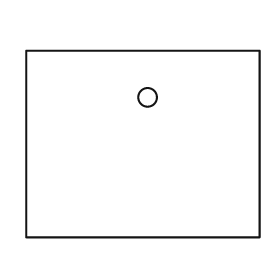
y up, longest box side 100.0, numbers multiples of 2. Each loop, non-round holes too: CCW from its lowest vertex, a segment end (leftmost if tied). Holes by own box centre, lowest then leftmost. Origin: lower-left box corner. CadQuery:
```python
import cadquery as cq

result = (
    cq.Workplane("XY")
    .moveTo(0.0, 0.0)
    .lineTo(100.0, 0.0)
    .lineTo(100.0, 80.0)
    .lineTo(0.0, 80.0)
    .close()
    .moveTo(52.0, 60.0)
    .circle(4.0)
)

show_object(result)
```